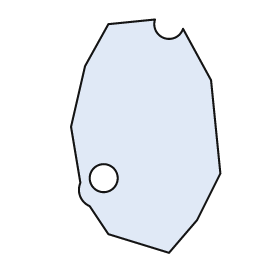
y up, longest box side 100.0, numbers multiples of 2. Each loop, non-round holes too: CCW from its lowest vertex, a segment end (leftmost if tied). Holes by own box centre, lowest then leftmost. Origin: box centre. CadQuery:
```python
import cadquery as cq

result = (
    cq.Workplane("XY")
    .moveTo(10.0, -50.0)
    .lineTo(22.0, -36.0)
    .lineTo(32.0, -16.0)
    .lineTo(28.0, 24.0)
    .lineTo(16.0, 46.0)
    .threePointArc((8.0, 42.0), (4.0, 50.0))
    .lineTo(-16.0, 48.0)
    .lineTo(-26.0, 30.0)
    .lineTo(-32.0, 4.0)
    .lineTo(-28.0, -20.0)
    .threePointArc((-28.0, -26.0), (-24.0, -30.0))
    .lineTo(-16.0, -42.0)
    .close()
    .moveTo(-18.0, -18.0)
    .circle(6.0)
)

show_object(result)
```